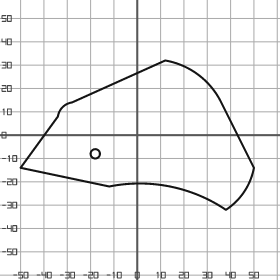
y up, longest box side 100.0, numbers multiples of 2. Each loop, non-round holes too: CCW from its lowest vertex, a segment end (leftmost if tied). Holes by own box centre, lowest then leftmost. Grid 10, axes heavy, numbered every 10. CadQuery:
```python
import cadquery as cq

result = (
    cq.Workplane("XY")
    .moveTo(38.0, -32.0)
    .threePointArc((46.0, -24.0), (50.0, -14.0))
    .lineTo(36.0, 14.0)
    .threePointArc((26.0, 26.0), (12.0, 32.0))
    .lineTo(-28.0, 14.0)
    .threePointArc((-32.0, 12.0), (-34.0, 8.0))
    .lineTo(-50.0, -14.0)
    .lineTo(-12.0, -22.0)
    .threePointArc((14.0, -22.0), (38.0, -32.0))
    .close()
    .moveTo(-18.0, -8.0)
    .circle(2.0)
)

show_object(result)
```